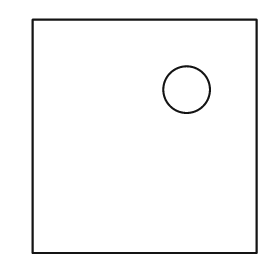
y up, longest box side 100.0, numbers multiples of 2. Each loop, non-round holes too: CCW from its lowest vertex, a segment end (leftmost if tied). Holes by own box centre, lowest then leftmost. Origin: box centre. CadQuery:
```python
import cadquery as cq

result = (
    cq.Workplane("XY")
    .moveTo(-48.0, -50.0)
    .lineTo(48.0, -50.0)
    .lineTo(48.0, 50.0)
    .lineTo(-48.0, 50.0)
    .close()
    .moveTo(18.0, 20.0)
    .circle(10.0)
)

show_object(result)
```